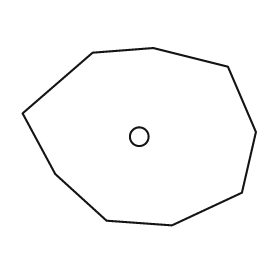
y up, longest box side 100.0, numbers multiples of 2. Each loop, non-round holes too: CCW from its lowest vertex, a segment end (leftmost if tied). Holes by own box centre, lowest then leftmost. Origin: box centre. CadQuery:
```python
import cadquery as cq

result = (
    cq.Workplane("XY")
    .moveTo(14.0, -38.0)
    .lineTo(44.0, -24.0)
    .lineTo(50.0, 2.0)
    .lineTo(38.0, 30.0)
    .lineTo(6.0, 38.0)
    .lineTo(-20.0, 36.0)
    .lineTo(-50.0, 10.0)
    .lineTo(-36.0, -16.0)
    .lineTo(-14.0, -36.0)
    .close()
    .moveTo(0.0, 0.0)
    .circle(4.0)
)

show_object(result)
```